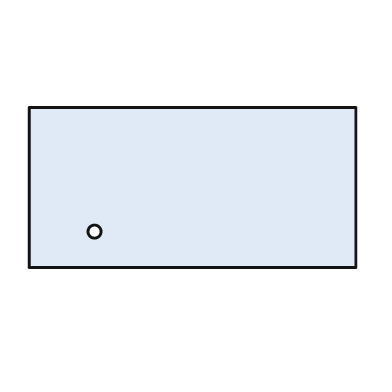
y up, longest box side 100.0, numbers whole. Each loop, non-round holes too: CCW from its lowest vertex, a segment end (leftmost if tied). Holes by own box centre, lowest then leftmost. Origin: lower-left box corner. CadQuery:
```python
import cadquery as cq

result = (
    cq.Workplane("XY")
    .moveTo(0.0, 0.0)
    .lineTo(100.0, 0.0)
    .lineTo(100.0, 49.0)
    .lineTo(0.0, 49.0)
    .close()
    .moveTo(20.0, 11.0)
    .circle(2.0)
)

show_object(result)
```